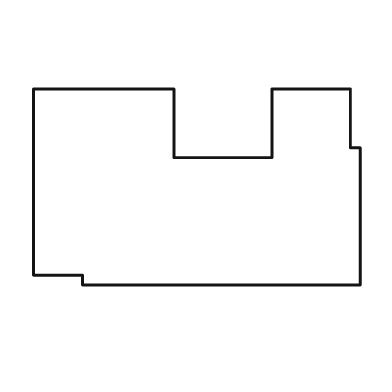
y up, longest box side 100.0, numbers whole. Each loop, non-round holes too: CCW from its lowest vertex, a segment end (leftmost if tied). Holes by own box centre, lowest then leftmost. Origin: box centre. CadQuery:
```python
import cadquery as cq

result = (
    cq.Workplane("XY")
    .moveTo(-35.0, -30.0)
    .lineTo(50.0, -30.0)
    .lineTo(50.0, 12.0)
    .lineTo(47.0, 12.0)
    .lineTo(47.0, 30.0)
    .lineTo(23.0, 30.0)
    .lineTo(23.0, 9.0)
    .lineTo(-7.0, 9.0)
    .lineTo(-7.0, 30.0)
    .lineTo(-50.0, 30.0)
    .lineTo(-50.0, -27.0)
    .lineTo(-35.0, -27.0)
    .close()
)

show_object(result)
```